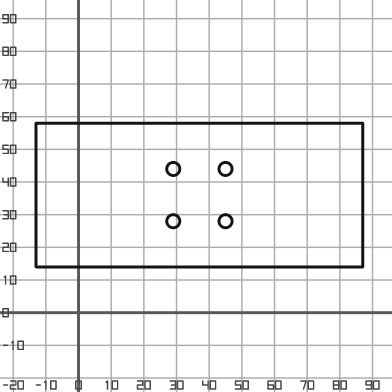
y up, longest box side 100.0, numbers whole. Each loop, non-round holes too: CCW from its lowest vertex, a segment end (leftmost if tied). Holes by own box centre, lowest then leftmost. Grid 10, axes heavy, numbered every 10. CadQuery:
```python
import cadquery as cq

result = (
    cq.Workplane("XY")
    .moveTo(-13.0, 14.0)
    .lineTo(87.0, 14.0)
    .lineTo(87.0, 58.0)
    .lineTo(-13.0, 58.0)
    .close()
    .moveTo(29.0, 28.0)
    .circle(2.0)
    .moveTo(45.0, 28.0)
    .circle(2.0)
    .moveTo(29.0, 44.0)
    .circle(2.0)
    .moveTo(45.0, 44.0)
    .circle(2.0)
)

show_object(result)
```